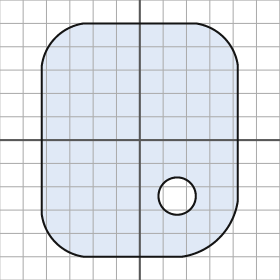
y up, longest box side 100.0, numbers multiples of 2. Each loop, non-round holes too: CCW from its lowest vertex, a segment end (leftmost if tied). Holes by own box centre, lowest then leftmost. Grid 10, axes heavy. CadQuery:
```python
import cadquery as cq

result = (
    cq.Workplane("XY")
    .moveTo(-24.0, -50.0)
    .lineTo(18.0, -50.0)
    .threePointArc((34.0, -42.0), (42.0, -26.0))
    .lineTo(42.0, 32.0)
    .threePointArc((36.0, 44.0), (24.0, 50.0))
    .lineTo(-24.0, 50.0)
    .threePointArc((-36.0, 44.0), (-42.0, 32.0))
    .lineTo(-42.0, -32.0)
    .threePointArc((-36.0, -44.0), (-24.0, -50.0))
    .close()
    .moveTo(16.0, -24.0)
    .circle(8.0)
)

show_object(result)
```